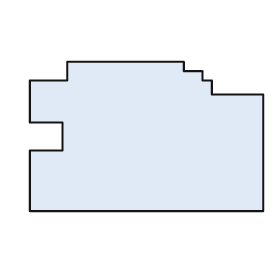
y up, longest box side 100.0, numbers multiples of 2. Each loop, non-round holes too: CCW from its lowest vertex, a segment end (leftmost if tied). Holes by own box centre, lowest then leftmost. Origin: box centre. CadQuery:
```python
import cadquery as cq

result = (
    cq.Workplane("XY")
    .moveTo(-50.0, -32.0)
    .lineTo(50.0, -32.0)
    .lineTo(50.0, 18.0)
    .lineTo(28.0, 18.0)
    .lineTo(28.0, 24.0)
    .lineTo(24.0, 24.0)
    .lineTo(24.0, 28.0)
    .lineTo(16.0, 28.0)
    .lineTo(16.0, 32.0)
    .lineTo(-34.0, 32.0)
    .lineTo(-34.0, 24.0)
    .lineTo(-50.0, 24.0)
    .lineTo(-50.0, 6.0)
    .lineTo(-36.0, 6.0)
    .lineTo(-36.0, -6.0)
    .lineTo(-50.0, -6.0)
    .close()
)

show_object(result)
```